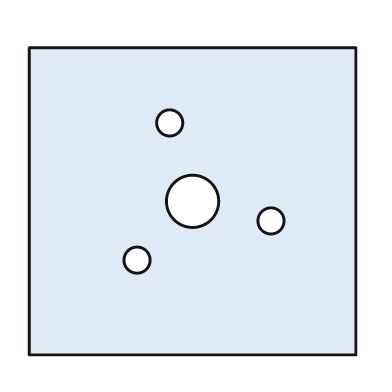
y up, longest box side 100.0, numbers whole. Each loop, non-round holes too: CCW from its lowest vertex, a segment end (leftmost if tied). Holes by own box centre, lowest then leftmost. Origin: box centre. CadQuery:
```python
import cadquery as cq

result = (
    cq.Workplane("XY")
    .moveTo(-50.0, -47.0)
    .lineTo(50.0, -47.0)
    .lineTo(50.0, 47.0)
    .lineTo(-50.0, 47.0)
    .close()
    .moveTo(-17.0, -18.0)
    .circle(4.0)
    .moveTo(24.0, -6.0)
    .circle(4.0)
    .moveTo(0.0, 0.0)
    .circle(8.0)
    .moveTo(-7.0, 24.0)
    .circle(4.0)
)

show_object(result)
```